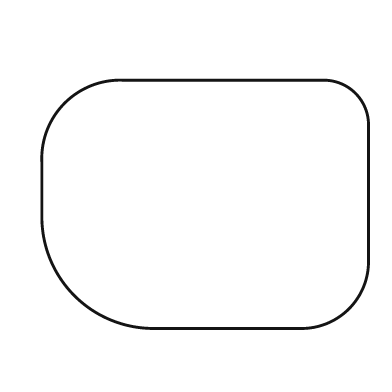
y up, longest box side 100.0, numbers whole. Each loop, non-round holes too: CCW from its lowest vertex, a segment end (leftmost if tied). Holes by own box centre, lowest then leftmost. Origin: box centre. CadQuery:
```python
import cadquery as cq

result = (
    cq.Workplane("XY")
    .moveTo(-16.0, -38.0)
    .lineTo(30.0, -38.0)
    .threePointArc((44.0, -32.0), (50.0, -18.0))
    .lineTo(50.0, 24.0)
    .threePointArc((46.0, 34.0), (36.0, 38.0))
    .lineTo(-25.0, 38.0)
    .threePointArc((-43.0, 31.0), (-50.0, 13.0))
    .lineTo(-50.0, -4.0)
    .threePointArc((-40.0, -28.0), (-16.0, -38.0))
    .close()
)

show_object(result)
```